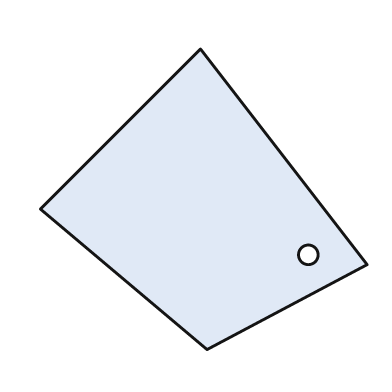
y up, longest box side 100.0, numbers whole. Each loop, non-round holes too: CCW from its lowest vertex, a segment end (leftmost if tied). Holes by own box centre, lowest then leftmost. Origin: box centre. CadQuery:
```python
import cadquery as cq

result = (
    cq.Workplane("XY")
    .moveTo(1.0, -46.0)
    .lineTo(50.0, -20.0)
    .lineTo(-1.0, 46.0)
    .lineTo(-50.0, -3.0)
    .close()
    .moveTo(32.0, -17.0)
    .circle(3.0)
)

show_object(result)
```